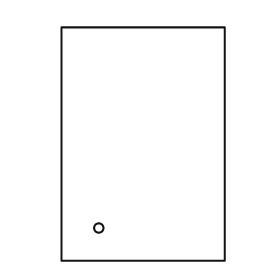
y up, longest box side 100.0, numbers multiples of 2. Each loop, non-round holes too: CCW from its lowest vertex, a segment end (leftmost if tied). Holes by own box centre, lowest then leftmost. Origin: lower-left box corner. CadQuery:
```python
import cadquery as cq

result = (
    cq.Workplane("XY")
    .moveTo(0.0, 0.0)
    .lineTo(70.0, 0.0)
    .lineTo(70.0, 100.0)
    .lineTo(0.0, 100.0)
    .close()
    .moveTo(16.0, 14.0)
    .circle(2.0)
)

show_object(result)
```